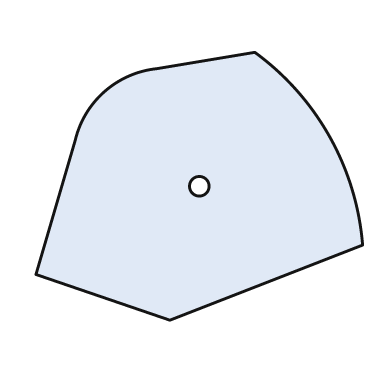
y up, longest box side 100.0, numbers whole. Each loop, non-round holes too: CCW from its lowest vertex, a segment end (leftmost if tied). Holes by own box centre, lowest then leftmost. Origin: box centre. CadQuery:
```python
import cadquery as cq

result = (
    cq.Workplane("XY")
    .moveTo(-9.0, -41.0)
    .lineTo(50.0, -18.0)
    .threePointArc((40.0, 15.0), (17.0, 41.0))
    .lineTo(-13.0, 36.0)
    .threePointArc((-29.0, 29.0), (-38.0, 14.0))
    .lineTo(-50.0, -27.0)
    .close()
    .moveTo(0.0, 0.0)
    .circle(3.0)
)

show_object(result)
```